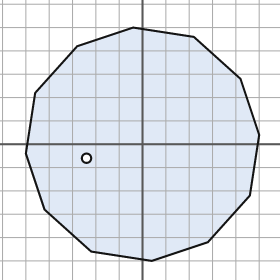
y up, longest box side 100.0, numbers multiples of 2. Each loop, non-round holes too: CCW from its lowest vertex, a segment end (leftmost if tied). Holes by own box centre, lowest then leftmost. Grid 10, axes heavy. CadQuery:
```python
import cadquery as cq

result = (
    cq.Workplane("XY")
    .moveTo(4.0, -50.0)
    .lineTo(28.0, -42.0)
    .lineTo(46.0, -22.0)
    .lineTo(50.0, 4.0)
    .lineTo(42.0, 28.0)
    .lineTo(22.0, 46.0)
    .lineTo(-4.0, 50.0)
    .lineTo(-28.0, 42.0)
    .lineTo(-46.0, 22.0)
    .lineTo(-50.0, -4.0)
    .lineTo(-42.0, -28.0)
    .lineTo(-22.0, -46.0)
    .close()
    .moveTo(-24.0, -6.0)
    .circle(2.0)
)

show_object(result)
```